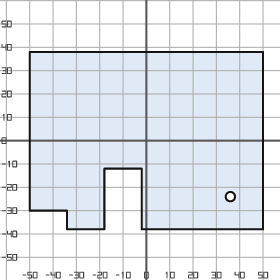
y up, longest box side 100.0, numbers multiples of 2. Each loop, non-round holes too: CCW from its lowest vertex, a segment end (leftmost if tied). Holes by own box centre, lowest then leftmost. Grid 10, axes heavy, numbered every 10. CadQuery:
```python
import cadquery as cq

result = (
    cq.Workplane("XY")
    .moveTo(-34.0, -38.0)
    .lineTo(-18.0, -38.0)
    .lineTo(-18.0, -12.0)
    .lineTo(-2.0, -12.0)
    .lineTo(-2.0, -38.0)
    .lineTo(50.0, -38.0)
    .lineTo(50.0, 38.0)
    .lineTo(-50.0, 38.0)
    .lineTo(-50.0, -30.0)
    .lineTo(-34.0, -30.0)
    .close()
    .moveTo(36.0, -24.0)
    .circle(2.0)
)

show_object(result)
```